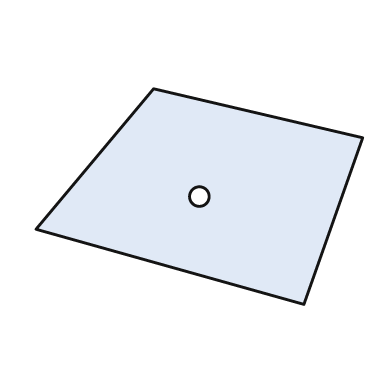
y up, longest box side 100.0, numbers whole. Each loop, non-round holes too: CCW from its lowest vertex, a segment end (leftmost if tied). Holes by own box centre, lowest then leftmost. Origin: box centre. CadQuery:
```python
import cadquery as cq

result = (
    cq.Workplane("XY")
    .moveTo(32.0, -33.0)
    .lineTo(50.0, 18.0)
    .lineTo(-14.0, 33.0)
    .lineTo(-50.0, -10.0)
    .close()
    .moveTo(0.0, 0.0)
    .circle(3.0)
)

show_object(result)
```